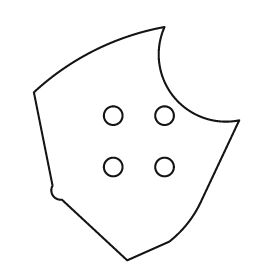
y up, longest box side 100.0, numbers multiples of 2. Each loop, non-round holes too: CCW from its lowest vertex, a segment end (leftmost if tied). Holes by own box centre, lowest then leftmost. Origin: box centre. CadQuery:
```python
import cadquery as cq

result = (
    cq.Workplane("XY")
    .moveTo(-4.0, -50.0)
    .lineTo(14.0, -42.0)
    .threePointArc((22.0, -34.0), (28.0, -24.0))
    .lineTo(44.0, 10.0)
    .threePointArc((16.0, 20.0), (12.0, 50.0))
    .threePointArc((-18.0, 40.0), (-44.0, 22.0))
    .lineTo(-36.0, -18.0)
    .threePointArc((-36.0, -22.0), (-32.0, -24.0))
    .close()
    .moveTo(-10.0, -10.0)
    .circle(4.0)
    .moveTo(12.0, -10.0)
    .circle(4.0)
    .moveTo(-10.0, 12.0)
    .circle(4.0)
    .moveTo(12.0, 12.0)
    .circle(4.0)
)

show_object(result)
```